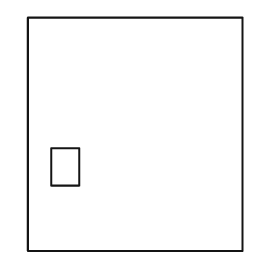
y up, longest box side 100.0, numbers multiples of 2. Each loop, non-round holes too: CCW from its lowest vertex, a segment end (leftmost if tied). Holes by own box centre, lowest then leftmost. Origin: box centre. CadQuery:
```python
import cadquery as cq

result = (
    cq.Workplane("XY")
    .moveTo(-46.0, -50.0)
    .lineTo(46.0, -50.0)
    .lineTo(46.0, 50.0)
    .lineTo(-46.0, 50.0)
    .close()
    .moveTo(-36.0, -22.0)
    .lineTo(-24.0, -22.0)
    .lineTo(-24.0, -6.0)
    .lineTo(-36.0, -6.0)
    .close()
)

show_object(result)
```